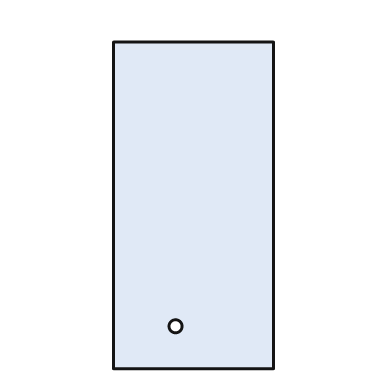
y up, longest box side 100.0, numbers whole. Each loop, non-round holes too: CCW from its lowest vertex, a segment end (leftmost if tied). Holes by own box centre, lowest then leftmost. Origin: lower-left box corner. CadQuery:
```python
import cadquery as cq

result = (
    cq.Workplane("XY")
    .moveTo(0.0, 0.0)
    .lineTo(49.0, 0.0)
    .lineTo(49.0, 100.0)
    .lineTo(0.0, 100.0)
    .close()
    .moveTo(19.0, 13.0)
    .circle(2.0)
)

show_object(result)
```